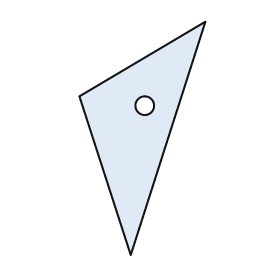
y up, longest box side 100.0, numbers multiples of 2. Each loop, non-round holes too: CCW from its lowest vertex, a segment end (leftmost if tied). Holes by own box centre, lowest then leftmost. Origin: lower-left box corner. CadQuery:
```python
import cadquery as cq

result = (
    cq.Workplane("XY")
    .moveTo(22.0, 0.0)
    .lineTo(54.0, 100.0)
    .lineTo(0.0, 68.0)
    .close()
    .moveTo(28.0, 64.0)
    .circle(4.0)
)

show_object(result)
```